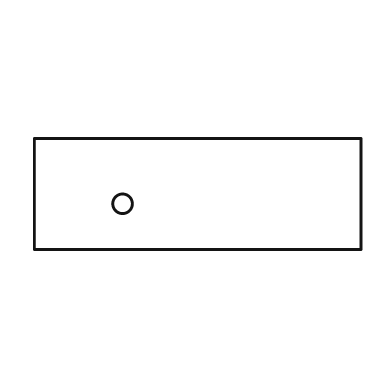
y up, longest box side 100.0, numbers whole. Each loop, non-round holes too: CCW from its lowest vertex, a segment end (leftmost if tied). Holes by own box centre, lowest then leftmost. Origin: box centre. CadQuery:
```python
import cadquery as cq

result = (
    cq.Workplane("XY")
    .moveTo(-50.0, -17.0)
    .lineTo(50.0, -17.0)
    .lineTo(50.0, 17.0)
    .lineTo(-50.0, 17.0)
    .close()
    .moveTo(-23.0, -3.0)
    .circle(3.0)
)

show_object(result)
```